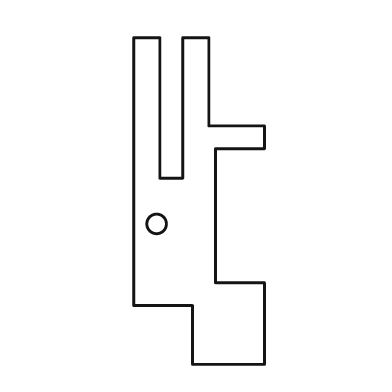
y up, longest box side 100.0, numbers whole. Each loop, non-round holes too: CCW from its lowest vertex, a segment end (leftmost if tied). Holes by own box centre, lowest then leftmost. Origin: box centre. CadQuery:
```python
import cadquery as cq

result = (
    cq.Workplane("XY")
    .moveTo(-2.0, -50.0)
    .lineTo(20.0, -50.0)
    .lineTo(20.0, -25.0)
    .lineTo(5.0, -25.0)
    .lineTo(5.0, 16.0)
    .lineTo(20.0, 16.0)
    .lineTo(20.0, 23.0)
    .lineTo(3.0, 23.0)
    .lineTo(3.0, 50.0)
    .lineTo(-5.0, 50.0)
    .lineTo(-5.0, 7.0)
    .lineTo(-12.0, 7.0)
    .lineTo(-12.0, 50.0)
    .lineTo(-20.0, 50.0)
    .lineTo(-20.0, -32.0)
    .lineTo(-2.0, -32.0)
    .close()
    .moveTo(-13.0, -7.0)
    .circle(3.0)
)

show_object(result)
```